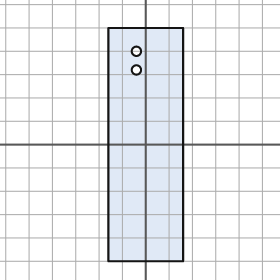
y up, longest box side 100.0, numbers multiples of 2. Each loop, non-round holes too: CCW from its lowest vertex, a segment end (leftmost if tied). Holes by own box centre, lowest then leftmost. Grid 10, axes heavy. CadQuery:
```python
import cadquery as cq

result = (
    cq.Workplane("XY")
    .moveTo(-16.0, -50.0)
    .lineTo(16.0, -50.0)
    .lineTo(16.0, 50.0)
    .lineTo(-16.0, 50.0)
    .close()
    .moveTo(-4.0, 32.0)
    .circle(2.0)
    .moveTo(-4.0, 40.0)
    .circle(2.0)
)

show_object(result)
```